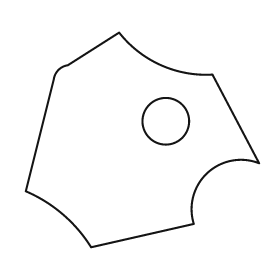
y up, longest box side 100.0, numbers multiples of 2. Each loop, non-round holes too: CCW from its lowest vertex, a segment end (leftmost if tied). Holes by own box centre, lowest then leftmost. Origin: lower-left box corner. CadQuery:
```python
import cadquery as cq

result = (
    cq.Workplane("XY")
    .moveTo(28.0, 0.0)
    .lineTo(72.0, 10.0)
    .threePointArc((78.0, 32.0), (100.0, 36.0))
    .lineTo(80.0, 74.0)
    .threePointArc((58.0, 78.0), (40.0, 92.0))
    .lineTo(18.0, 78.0)
    .threePointArc((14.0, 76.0), (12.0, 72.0))
    .lineTo(0.0, 24.0)
    .threePointArc((16.0, 14.0), (28.0, 0.0))
    .close()
    .moveTo(60.0, 54.0)
    .circle(10.0)
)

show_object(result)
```